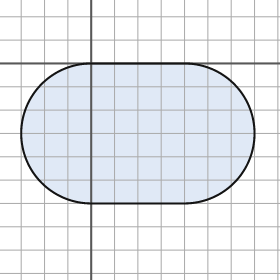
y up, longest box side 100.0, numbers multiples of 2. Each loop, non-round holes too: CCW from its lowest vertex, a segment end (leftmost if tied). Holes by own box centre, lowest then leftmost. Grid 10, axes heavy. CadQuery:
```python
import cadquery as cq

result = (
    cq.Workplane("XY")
    .moveTo(0.0, -60.0)
    .lineTo(40.0, -60.0)
    .threePointArc((70.0, -30.0), (40.0, 0.0))
    .lineTo(0.0, 0.0)
    .threePointArc((-30.0, -30.0), (0.0, -60.0))
    .close()
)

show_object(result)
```